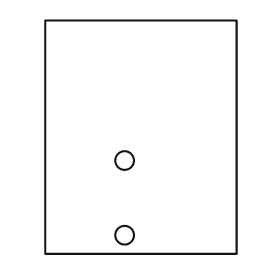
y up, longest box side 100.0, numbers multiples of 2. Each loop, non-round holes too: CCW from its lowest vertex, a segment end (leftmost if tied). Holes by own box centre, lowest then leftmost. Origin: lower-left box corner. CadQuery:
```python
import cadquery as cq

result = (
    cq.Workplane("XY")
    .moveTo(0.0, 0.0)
    .lineTo(82.0, 0.0)
    .lineTo(82.0, 100.0)
    .lineTo(0.0, 100.0)
    .close()
    .moveTo(34.0, 8.0)
    .circle(4.0)
    .moveTo(34.0, 40.0)
    .circle(4.0)
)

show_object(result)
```